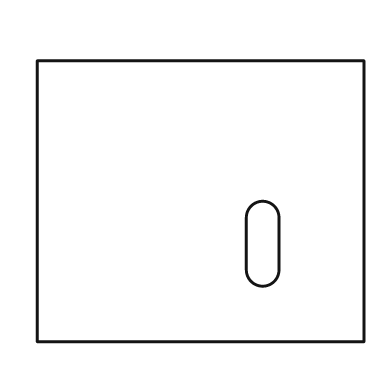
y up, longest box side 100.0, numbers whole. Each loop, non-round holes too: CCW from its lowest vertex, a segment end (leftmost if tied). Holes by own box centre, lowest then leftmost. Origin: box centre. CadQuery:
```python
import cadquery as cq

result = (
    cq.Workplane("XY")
    .moveTo(-50.0, -43.0)
    .lineTo(50.0, -43.0)
    .lineTo(50.0, 43.0)
    .lineTo(-50.0, 43.0)
    .close()
    .moveTo(14.0, -21.0)
    .threePointArc((19.0, -26.0), (24.0, -21.0))
    .lineTo(24.0, -5.0)
    .threePointArc((19.0, 0.0), (14.0, -5.0))
    .close()
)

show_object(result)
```